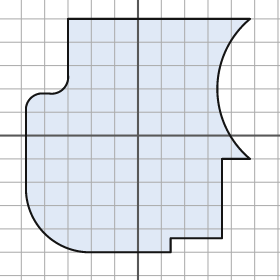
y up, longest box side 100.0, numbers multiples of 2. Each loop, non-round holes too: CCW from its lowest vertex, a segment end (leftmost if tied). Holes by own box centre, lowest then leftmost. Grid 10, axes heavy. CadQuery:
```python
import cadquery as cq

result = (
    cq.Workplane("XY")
    .moveTo(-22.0, -50.0)
    .lineTo(14.0, -50.0)
    .lineTo(14.0, -44.0)
    .lineTo(36.0, -44.0)
    .lineTo(36.0, -10.0)
    .lineTo(48.0, -10.0)
    .threePointArc((34.0, 20.0), (48.0, 50.0))
    .lineTo(-30.0, 50.0)
    .lineTo(-30.0, 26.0)
    .threePointArc((-32.0, 20.0), (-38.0, 18.0))
    .lineTo(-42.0, 18.0)
    .threePointArc((-46.0, 16.0), (-48.0, 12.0))
    .lineTo(-48.0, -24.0)
    .threePointArc((-40.0, -42.0), (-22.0, -50.0))
    .close()
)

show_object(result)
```